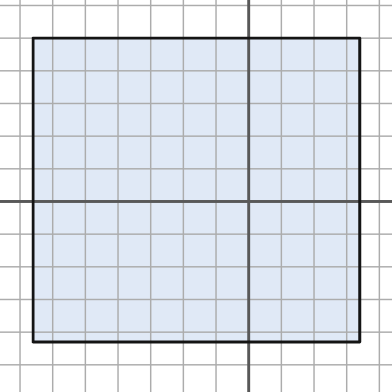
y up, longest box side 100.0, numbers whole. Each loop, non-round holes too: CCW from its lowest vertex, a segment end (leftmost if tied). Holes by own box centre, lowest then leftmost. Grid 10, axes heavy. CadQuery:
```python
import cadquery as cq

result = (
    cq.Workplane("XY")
    .moveTo(-66.0, -43.0)
    .lineTo(34.0, -43.0)
    .lineTo(34.0, 50.0)
    .lineTo(-66.0, 50.0)
    .close()
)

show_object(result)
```